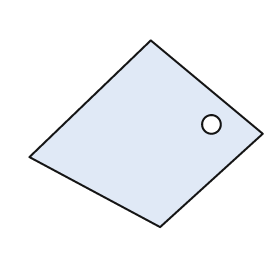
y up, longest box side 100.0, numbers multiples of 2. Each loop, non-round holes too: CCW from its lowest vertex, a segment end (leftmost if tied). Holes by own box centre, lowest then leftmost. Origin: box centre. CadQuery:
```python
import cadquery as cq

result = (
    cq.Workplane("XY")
    .moveTo(6.0, -40.0)
    .lineTo(50.0, 0.0)
    .lineTo(2.0, 40.0)
    .lineTo(-50.0, -10.0)
    .close()
    .moveTo(28.0, 4.0)
    .circle(4.0)
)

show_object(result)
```